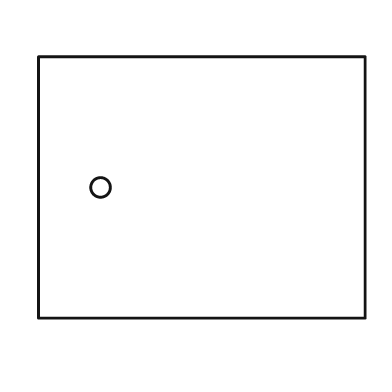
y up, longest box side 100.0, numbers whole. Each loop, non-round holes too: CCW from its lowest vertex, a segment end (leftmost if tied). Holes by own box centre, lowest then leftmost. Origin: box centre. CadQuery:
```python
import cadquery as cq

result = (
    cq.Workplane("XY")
    .moveTo(-50.0, -40.0)
    .lineTo(50.0, -40.0)
    .lineTo(50.0, 40.0)
    .lineTo(-50.0, 40.0)
    .close()
    .moveTo(-31.0, 0.0)
    .circle(3.0)
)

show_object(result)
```